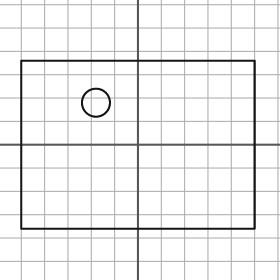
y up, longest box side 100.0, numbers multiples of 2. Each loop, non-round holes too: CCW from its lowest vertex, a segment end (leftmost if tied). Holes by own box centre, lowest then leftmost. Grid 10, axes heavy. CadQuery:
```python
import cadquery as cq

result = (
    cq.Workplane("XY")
    .moveTo(-50.0, -36.0)
    .lineTo(50.0, -36.0)
    .lineTo(50.0, 36.0)
    .lineTo(-50.0, 36.0)
    .close()
    .moveTo(-18.0, 18.0)
    .circle(6.0)
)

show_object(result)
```